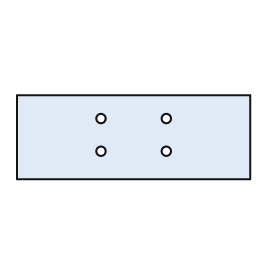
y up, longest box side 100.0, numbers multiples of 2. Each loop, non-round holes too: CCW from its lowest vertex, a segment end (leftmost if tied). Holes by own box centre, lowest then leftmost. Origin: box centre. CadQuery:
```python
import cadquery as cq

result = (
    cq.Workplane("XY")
    .moveTo(-50.0, -18.0)
    .lineTo(50.0, -18.0)
    .lineTo(50.0, 18.0)
    .lineTo(-50.0, 18.0)
    .close()
    .moveTo(-14.0, -6.0)
    .circle(2.0)
    .moveTo(14.0, -6.0)
    .circle(2.0)
    .moveTo(-14.0, 8.0)
    .circle(2.0)
    .moveTo(14.0, 8.0)
    .circle(2.0)
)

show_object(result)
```